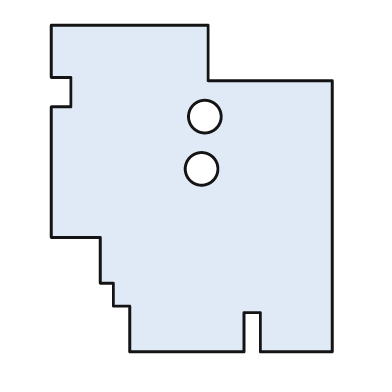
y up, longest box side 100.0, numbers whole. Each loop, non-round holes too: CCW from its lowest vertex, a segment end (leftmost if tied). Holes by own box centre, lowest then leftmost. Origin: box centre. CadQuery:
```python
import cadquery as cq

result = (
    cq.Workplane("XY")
    .moveTo(-19.0, -50.0)
    .lineTo(16.0, -50.0)
    .lineTo(16.0, -38.0)
    .lineTo(21.0, -38.0)
    .lineTo(21.0, -50.0)
    .lineTo(43.0, -50.0)
    .lineTo(43.0, 33.0)
    .lineTo(5.0, 33.0)
    .lineTo(5.0, 50.0)
    .lineTo(-43.0, 50.0)
    .lineTo(-43.0, 34.0)
    .lineTo(-37.0, 34.0)
    .lineTo(-37.0, 25.0)
    .lineTo(-43.0, 25.0)
    .lineTo(-43.0, -15.0)
    .lineTo(-28.0, -15.0)
    .lineTo(-28.0, -29.0)
    .lineTo(-24.0, -29.0)
    .lineTo(-24.0, -36.0)
    .lineTo(-19.0, -36.0)
    .close()
    .moveTo(3.0, 6.0)
    .circle(5.0)
    .moveTo(4.0, 22.0)
    .circle(5.0)
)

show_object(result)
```